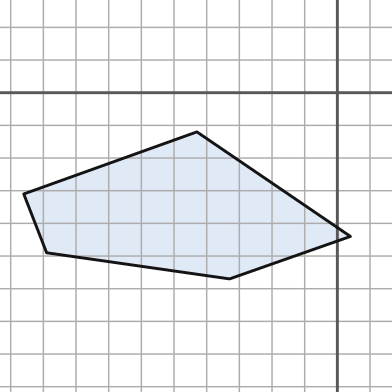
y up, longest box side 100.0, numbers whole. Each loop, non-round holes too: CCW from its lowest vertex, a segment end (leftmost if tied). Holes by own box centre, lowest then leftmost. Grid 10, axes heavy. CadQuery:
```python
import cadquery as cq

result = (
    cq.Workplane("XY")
    .moveTo(-33.0, -57.0)
    .lineTo(4.0, -44.0)
    .lineTo(-43.0, -12.0)
    .lineTo(-96.0, -31.0)
    .lineTo(-89.0, -49.0)
    .close()
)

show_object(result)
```